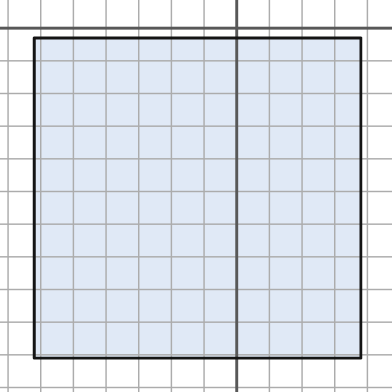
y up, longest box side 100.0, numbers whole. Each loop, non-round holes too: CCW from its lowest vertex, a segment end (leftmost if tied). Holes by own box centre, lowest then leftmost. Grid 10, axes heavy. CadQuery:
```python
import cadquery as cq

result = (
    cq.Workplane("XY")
    .moveTo(-62.0, -101.0)
    .lineTo(38.0, -101.0)
    .lineTo(38.0, -3.0)
    .lineTo(-62.0, -3.0)
    .close()
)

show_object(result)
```